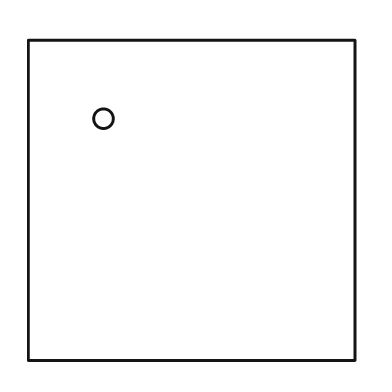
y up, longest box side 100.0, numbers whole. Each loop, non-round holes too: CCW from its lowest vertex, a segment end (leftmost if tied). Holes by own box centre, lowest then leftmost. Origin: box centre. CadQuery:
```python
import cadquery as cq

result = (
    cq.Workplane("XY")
    .moveTo(-50.0, -49.0)
    .lineTo(50.0, -49.0)
    .lineTo(50.0, 49.0)
    .lineTo(-50.0, 49.0)
    .close()
    .moveTo(-27.0, 25.0)
    .circle(3.0)
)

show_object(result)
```